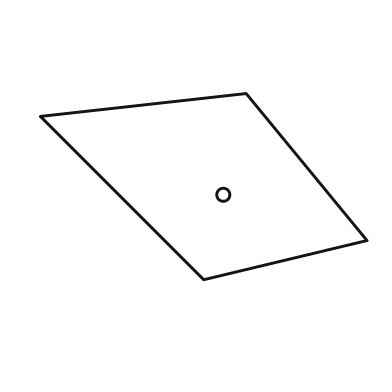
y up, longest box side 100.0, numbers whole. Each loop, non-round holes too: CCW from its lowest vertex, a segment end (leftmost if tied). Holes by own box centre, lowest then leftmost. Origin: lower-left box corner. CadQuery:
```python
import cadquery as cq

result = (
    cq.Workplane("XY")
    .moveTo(50.0, 0.0)
    .lineTo(100.0, 12.0)
    .lineTo(63.0, 57.0)
    .lineTo(0.0, 50.0)
    .close()
    .moveTo(56.0, 26.0)
    .circle(2.0)
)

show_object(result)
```